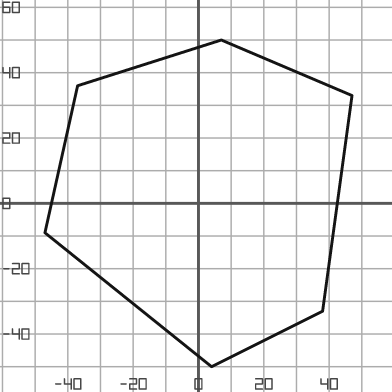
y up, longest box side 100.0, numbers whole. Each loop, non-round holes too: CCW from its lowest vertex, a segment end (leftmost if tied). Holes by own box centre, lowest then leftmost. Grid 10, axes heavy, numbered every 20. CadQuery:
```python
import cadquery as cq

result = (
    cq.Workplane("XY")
    .moveTo(4.0, -50.0)
    .lineTo(38.0, -33.0)
    .lineTo(47.0, 33.0)
    .lineTo(7.0, 50.0)
    .lineTo(-37.0, 36.0)
    .lineTo(-47.0, -9.0)
    .close()
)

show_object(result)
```